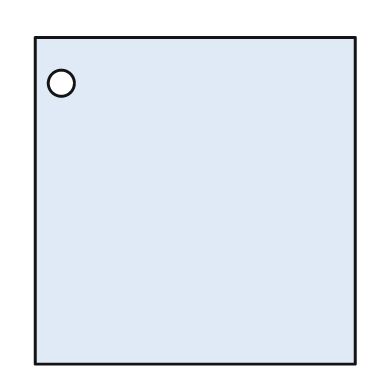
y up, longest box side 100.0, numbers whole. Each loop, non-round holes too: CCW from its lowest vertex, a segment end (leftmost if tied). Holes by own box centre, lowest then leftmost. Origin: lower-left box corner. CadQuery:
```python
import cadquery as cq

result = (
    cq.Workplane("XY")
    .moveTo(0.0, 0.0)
    .lineTo(98.0, 0.0)
    .lineTo(98.0, 100.0)
    .lineTo(0.0, 100.0)
    .close()
    .moveTo(8.0, 86.0)
    .circle(4.0)
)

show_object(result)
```